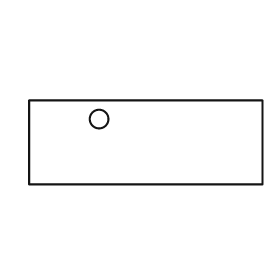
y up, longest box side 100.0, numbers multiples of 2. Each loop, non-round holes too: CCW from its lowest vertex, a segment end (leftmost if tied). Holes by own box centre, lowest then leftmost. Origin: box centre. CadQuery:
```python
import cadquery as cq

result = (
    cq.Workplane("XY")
    .moveTo(-50.0, -18.0)
    .lineTo(50.0, -18.0)
    .lineTo(50.0, 18.0)
    .lineTo(-50.0, 18.0)
    .close()
    .moveTo(-20.0, 10.0)
    .circle(4.0)
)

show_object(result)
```